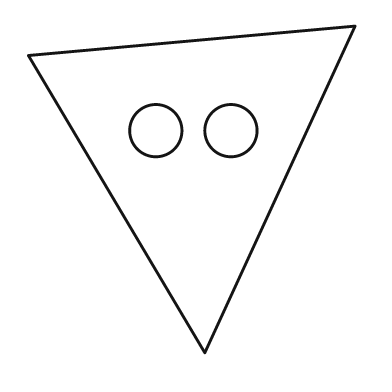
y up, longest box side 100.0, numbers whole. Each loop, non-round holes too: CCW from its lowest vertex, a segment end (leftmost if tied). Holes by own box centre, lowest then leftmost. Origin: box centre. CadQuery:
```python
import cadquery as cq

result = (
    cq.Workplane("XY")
    .moveTo(4.0, -50.0)
    .lineTo(50.0, 50.0)
    .lineTo(-50.0, 41.0)
    .close()
    .moveTo(-11.0, 18.0)
    .circle(8.0)
    .moveTo(12.0, 18.0)
    .circle(8.0)
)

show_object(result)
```